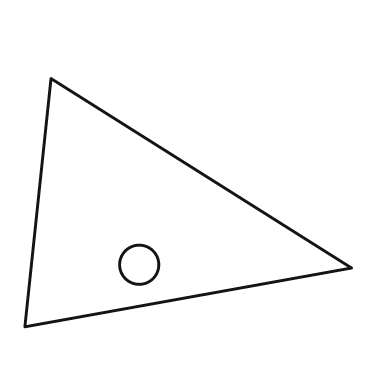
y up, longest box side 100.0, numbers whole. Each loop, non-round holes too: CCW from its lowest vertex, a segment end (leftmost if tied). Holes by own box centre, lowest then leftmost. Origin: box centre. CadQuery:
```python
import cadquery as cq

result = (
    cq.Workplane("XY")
    .moveTo(-50.0, -38.0)
    .lineTo(50.0, -20.0)
    .lineTo(-42.0, 38.0)
    .close()
    .moveTo(-15.0, -19.0)
    .circle(6.0)
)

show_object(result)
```